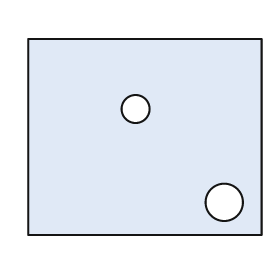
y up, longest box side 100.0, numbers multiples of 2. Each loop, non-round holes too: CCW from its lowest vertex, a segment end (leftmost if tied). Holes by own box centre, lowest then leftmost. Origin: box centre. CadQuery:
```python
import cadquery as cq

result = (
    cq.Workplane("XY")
    .moveTo(-50.0, -42.0)
    .lineTo(50.0, -42.0)
    .lineTo(50.0, 42.0)
    .lineTo(-50.0, 42.0)
    .close()
    .moveTo(34.0, -28.0)
    .circle(8.0)
    .moveTo(-4.0, 12.0)
    .circle(6.0)
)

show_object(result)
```